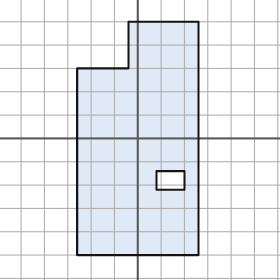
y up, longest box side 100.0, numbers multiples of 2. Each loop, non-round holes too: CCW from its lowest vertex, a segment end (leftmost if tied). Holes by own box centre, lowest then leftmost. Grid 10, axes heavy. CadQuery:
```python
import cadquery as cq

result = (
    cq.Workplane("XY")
    .moveTo(-26.0, -50.0)
    .lineTo(26.0, -50.0)
    .lineTo(26.0, 50.0)
    .lineTo(-4.0, 50.0)
    .lineTo(-4.0, 30.0)
    .lineTo(-26.0, 30.0)
    .close()
    .moveTo(8.0, -22.0)
    .lineTo(20.0, -22.0)
    .lineTo(20.0, -14.0)
    .lineTo(8.0, -14.0)
    .close()
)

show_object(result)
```